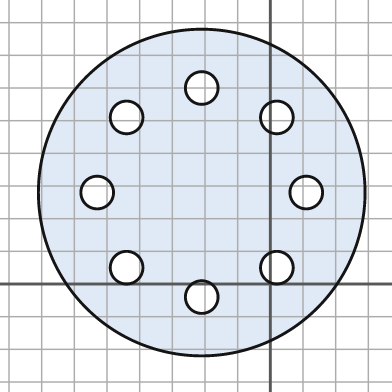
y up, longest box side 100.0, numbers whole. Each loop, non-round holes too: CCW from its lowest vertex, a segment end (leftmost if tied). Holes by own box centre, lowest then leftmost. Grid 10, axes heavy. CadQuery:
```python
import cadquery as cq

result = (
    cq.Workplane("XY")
    .moveTo(-21.0, 28.0)
    .circle(50.0)
    .moveTo(-21.0, -4.0)
    .circle(5.0)
    .moveTo(-44.0, 5.0)
    .circle(5.0)
    .moveTo(2.0, 5.0)
    .circle(5.0)
    .moveTo(-53.0, 28.0)
    .circle(5.0)
    .moveTo(11.0, 28.0)
    .circle(5.0)
    .moveTo(-44.0, 51.0)
    .circle(5.0)
    .moveTo(2.0, 51.0)
    .circle(5.0)
    .moveTo(-21.0, 60.0)
    .circle(5.0)
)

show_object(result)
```